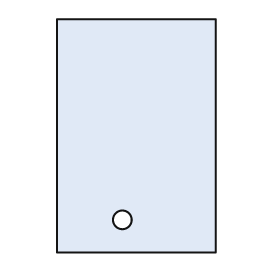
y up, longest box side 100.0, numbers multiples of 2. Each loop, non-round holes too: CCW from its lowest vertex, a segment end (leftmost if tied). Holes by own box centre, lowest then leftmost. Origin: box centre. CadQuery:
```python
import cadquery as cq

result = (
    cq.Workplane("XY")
    .moveTo(-34.0, -50.0)
    .lineTo(34.0, -50.0)
    .lineTo(34.0, 50.0)
    .lineTo(-34.0, 50.0)
    .close()
    .moveTo(-6.0, -36.0)
    .circle(4.0)
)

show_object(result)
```